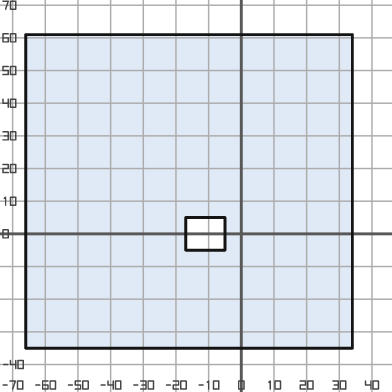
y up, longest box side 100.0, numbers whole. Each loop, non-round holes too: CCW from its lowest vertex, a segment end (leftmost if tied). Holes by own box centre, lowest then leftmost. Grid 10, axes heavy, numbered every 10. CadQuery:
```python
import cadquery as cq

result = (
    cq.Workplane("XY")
    .moveTo(-66.0, -35.0)
    .lineTo(34.0, -35.0)
    .lineTo(34.0, 61.0)
    .lineTo(-66.0, 61.0)
    .close()
    .moveTo(-17.0, -5.0)
    .lineTo(-5.0, -5.0)
    .lineTo(-5.0, 5.0)
    .lineTo(-17.0, 5.0)
    .close()
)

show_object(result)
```